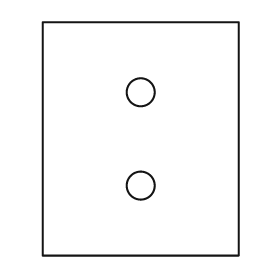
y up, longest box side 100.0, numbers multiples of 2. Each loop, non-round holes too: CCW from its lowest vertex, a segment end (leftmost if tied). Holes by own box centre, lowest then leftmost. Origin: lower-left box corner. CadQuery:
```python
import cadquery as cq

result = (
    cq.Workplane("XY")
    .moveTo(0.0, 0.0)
    .lineTo(84.0, 0.0)
    .lineTo(84.0, 100.0)
    .lineTo(0.0, 100.0)
    .close()
    .moveTo(42.0, 30.0)
    .circle(6.0)
    .moveTo(42.0, 70.0)
    .circle(6.0)
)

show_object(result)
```